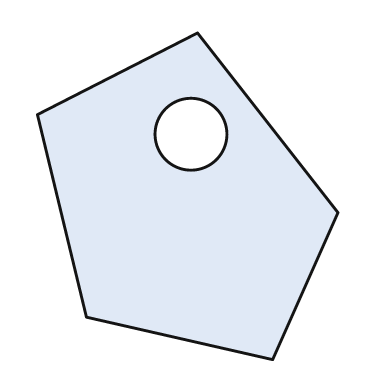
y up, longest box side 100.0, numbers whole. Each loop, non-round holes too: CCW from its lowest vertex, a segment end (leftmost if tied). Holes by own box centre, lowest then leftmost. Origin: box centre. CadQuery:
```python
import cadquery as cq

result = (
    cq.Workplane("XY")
    .moveTo(26.0, -50.0)
    .lineTo(46.0, -5.0)
    .lineTo(3.0, 50.0)
    .lineTo(-46.0, 25.0)
    .lineTo(-31.0, -37.0)
    .close()
    .moveTo(1.0, 19.0)
    .circle(11.0)
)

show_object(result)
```